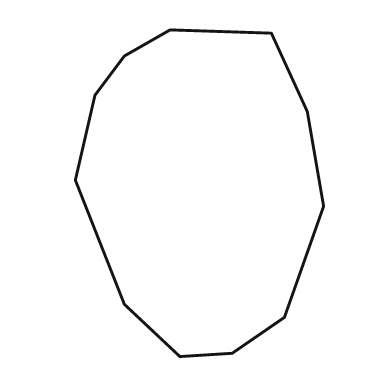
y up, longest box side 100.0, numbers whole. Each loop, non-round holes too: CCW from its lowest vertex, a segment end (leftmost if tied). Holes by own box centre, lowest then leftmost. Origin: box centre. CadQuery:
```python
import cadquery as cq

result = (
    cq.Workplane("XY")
    .moveTo(-6.0, -50.0)
    .lineTo(10.0, -49.0)
    .lineTo(26.0, -38.0)
    .lineTo(38.0, -4.0)
    .lineTo(33.0, 25.0)
    .lineTo(22.0, 49.0)
    .lineTo(-9.0, 50.0)
    .lineTo(-23.0, 42.0)
    .lineTo(-32.0, 30.0)
    .lineTo(-38.0, 4.0)
    .lineTo(-23.0, -34.0)
    .close()
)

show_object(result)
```